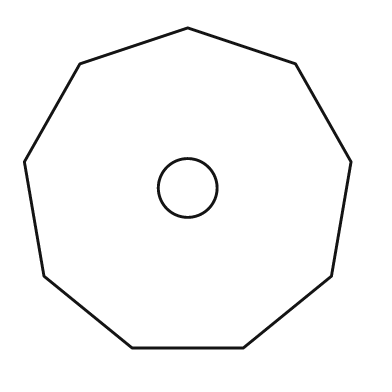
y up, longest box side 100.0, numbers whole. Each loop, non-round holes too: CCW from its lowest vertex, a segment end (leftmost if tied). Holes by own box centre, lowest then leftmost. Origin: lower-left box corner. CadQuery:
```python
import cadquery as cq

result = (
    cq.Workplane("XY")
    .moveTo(33.0, 0.0)
    .lineTo(67.0, 0.0)
    .lineTo(94.0, 22.0)
    .lineTo(100.0, 57.0)
    .lineTo(83.0, 87.0)
    .lineTo(50.0, 98.0)
    .lineTo(17.0, 87.0)
    .lineTo(0.0, 57.0)
    .lineTo(6.0, 22.0)
    .close()
    .moveTo(50.0, 49.0)
    .circle(9.0)
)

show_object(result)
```